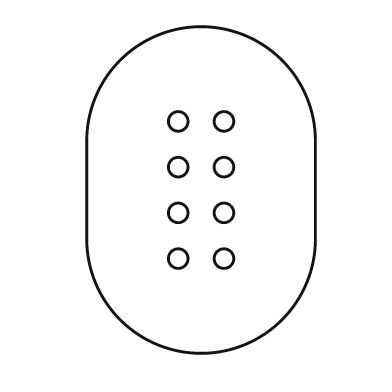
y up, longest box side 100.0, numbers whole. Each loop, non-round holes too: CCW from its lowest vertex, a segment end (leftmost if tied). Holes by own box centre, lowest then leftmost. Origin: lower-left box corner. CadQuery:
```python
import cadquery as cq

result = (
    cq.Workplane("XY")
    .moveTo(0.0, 35.0)
    .threePointArc((35.0, 0.0), (70.0, 35.0))
    .lineTo(70.0, 65.0)
    .threePointArc((35.0, 100.0), (0.0, 65.0))
    .close()
    .moveTo(28.0, 29.0)
    .circle(3.0)
    .moveTo(42.0, 29.0)
    .circle(3.0)
    .moveTo(28.0, 43.0)
    .circle(3.0)
    .moveTo(42.0, 43.0)
    .circle(3.0)
    .moveTo(28.0, 57.0)
    .circle(3.0)
    .moveTo(42.0, 57.0)
    .circle(3.0)
    .moveTo(28.0, 71.0)
    .circle(3.0)
    .moveTo(42.0, 71.0)
    .circle(3.0)
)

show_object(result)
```